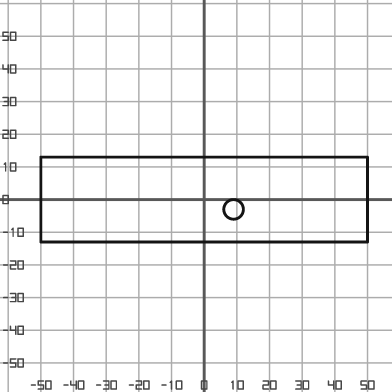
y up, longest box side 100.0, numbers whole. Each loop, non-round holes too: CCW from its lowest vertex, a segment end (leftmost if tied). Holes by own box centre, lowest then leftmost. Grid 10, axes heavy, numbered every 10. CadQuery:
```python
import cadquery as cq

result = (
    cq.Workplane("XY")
    .moveTo(-50.0, -13.0)
    .lineTo(50.0, -13.0)
    .lineTo(50.0, 13.0)
    .lineTo(-50.0, 13.0)
    .close()
    .moveTo(9.0, -3.0)
    .circle(3.0)
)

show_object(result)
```